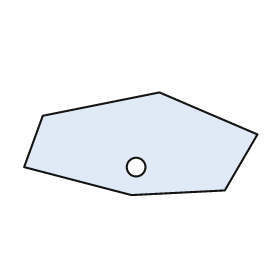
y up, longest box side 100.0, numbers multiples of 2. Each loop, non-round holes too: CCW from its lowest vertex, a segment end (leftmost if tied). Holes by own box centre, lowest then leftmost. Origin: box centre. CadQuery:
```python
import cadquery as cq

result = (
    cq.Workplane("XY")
    .moveTo(-4.0, -22.0)
    .lineTo(36.0, -20.0)
    .lineTo(50.0, 4.0)
    .lineTo(8.0, 22.0)
    .lineTo(-42.0, 12.0)
    .lineTo(-50.0, -10.0)
    .close()
    .moveTo(-2.0, -10.0)
    .circle(4.0)
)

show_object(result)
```